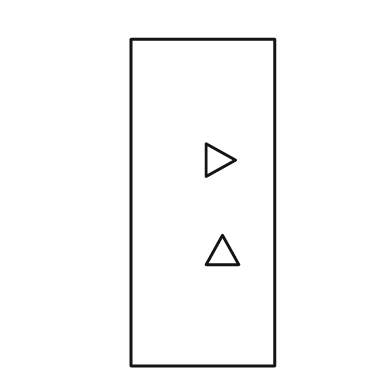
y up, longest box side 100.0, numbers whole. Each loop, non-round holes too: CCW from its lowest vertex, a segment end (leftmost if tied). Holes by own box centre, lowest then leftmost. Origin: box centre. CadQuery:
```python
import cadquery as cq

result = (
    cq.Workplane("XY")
    .moveTo(-22.0, -50.0)
    .lineTo(22.0, -50.0)
    .lineTo(22.0, 50.0)
    .lineTo(-22.0, 50.0)
    .close()
    .moveTo(1.0, -19.0)
    .lineTo(11.0, -19.0)
    .lineTo(6.0, -10.0)
    .close()
    .moveTo(1.0, 8.0)
    .lineTo(10.0, 13.0)
    .lineTo(1.0, 18.0)
    .close()
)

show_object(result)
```